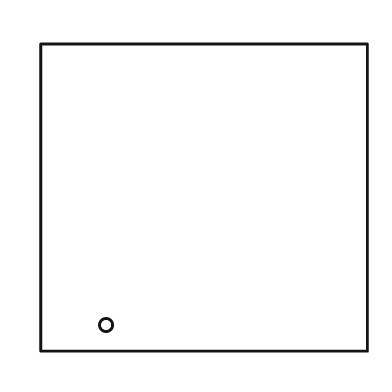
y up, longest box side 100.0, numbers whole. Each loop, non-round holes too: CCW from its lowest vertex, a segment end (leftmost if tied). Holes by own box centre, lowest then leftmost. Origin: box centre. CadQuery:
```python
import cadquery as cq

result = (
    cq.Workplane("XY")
    .moveTo(-50.0, -47.0)
    .lineTo(50.0, -47.0)
    .lineTo(50.0, 47.0)
    .lineTo(-50.0, 47.0)
    .close()
    .moveTo(-30.0, -39.0)
    .circle(2.0)
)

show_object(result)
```